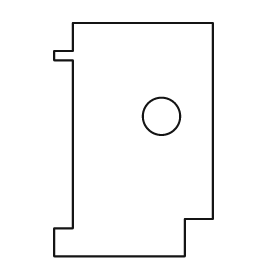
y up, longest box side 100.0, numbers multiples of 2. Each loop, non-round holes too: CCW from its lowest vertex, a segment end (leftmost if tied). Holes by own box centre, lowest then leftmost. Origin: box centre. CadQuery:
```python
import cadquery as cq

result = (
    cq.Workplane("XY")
    .moveTo(-34.0, -50.0)
    .lineTo(22.0, -50.0)
    .lineTo(22.0, -34.0)
    .lineTo(34.0, -34.0)
    .lineTo(34.0, 50.0)
    .lineTo(-26.0, 50.0)
    .lineTo(-26.0, 38.0)
    .lineTo(-34.0, 38.0)
    .lineTo(-34.0, 34.0)
    .lineTo(-26.0, 34.0)
    .lineTo(-26.0, -38.0)
    .lineTo(-34.0, -38.0)
    .close()
    .moveTo(12.0, 10.0)
    .circle(8.0)
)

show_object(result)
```